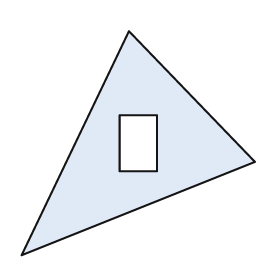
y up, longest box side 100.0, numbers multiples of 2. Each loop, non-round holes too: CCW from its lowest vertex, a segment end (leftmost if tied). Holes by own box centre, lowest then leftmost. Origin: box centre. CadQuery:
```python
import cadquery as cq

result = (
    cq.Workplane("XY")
    .moveTo(-50.0, -48.0)
    .lineTo(50.0, -8.0)
    .lineTo(-4.0, 48.0)
    .close()
    .moveTo(-8.0, -12.0)
    .lineTo(8.0, -12.0)
    .lineTo(8.0, 12.0)
    .lineTo(-8.0, 12.0)
    .close()
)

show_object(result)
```